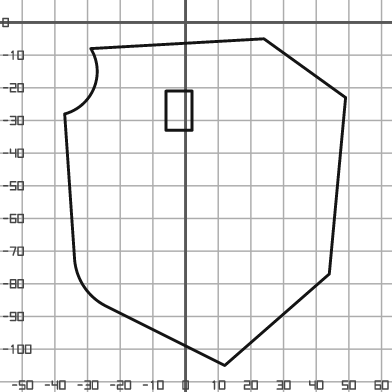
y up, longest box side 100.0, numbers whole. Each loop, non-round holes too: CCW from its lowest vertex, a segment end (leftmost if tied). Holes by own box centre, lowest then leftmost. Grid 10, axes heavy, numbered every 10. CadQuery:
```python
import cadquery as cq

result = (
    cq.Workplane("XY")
    .moveTo(12.0, -105.0)
    .lineTo(44.0, -77.0)
    .lineTo(49.0, -23.0)
    .lineTo(24.0, -5.0)
    .lineTo(-29.0, -8.0)
    .threePointArc((-28.0, -20.0), (-37.0, -28.0))
    .lineTo(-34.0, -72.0)
    .threePointArc((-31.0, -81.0), (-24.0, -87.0))
    .close()
    .moveTo(-6.0, -33.0)
    .lineTo(2.0, -33.0)
    .lineTo(2.0, -21.0)
    .lineTo(-6.0, -21.0)
    .close()
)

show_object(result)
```